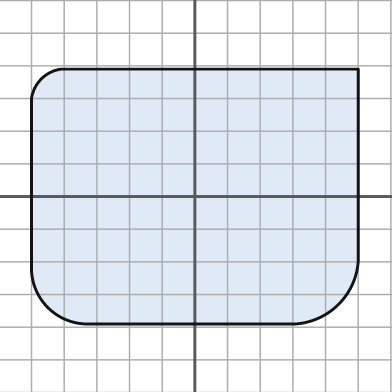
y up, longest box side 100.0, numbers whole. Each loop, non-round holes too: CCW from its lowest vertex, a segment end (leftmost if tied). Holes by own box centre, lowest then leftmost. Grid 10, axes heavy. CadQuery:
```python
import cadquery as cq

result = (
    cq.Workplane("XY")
    .moveTo(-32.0, -39.0)
    .lineTo(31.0, -39.0)
    .threePointArc((44.0, -33.0), (50.0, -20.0))
    .lineTo(50.0, 39.0)
    .lineTo(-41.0, 39.0)
    .threePointArc((-47.0, 36.0), (-50.0, 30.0))
    .lineTo(-50.0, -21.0)
    .threePointArc((-45.0, -34.0), (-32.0, -39.0))
    .close()
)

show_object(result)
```